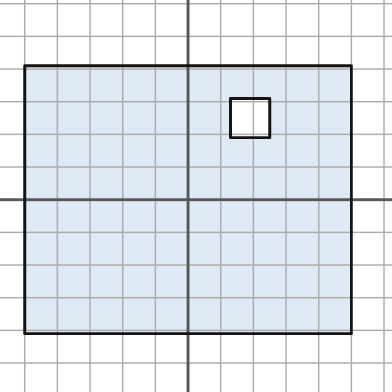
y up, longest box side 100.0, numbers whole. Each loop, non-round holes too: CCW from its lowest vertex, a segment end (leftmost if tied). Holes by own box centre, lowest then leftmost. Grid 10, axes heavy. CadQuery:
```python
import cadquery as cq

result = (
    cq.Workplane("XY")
    .moveTo(-50.0, -41.0)
    .lineTo(50.0, -41.0)
    .lineTo(50.0, 41.0)
    .lineTo(-50.0, 41.0)
    .close()
    .moveTo(13.0, 19.0)
    .lineTo(25.0, 19.0)
    .lineTo(25.0, 31.0)
    .lineTo(13.0, 31.0)
    .close()
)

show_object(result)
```